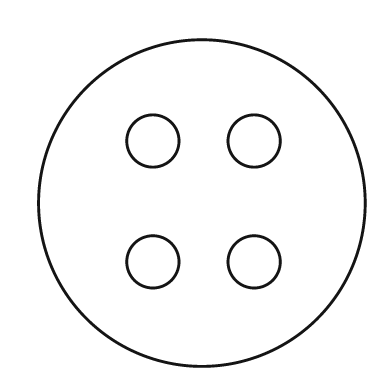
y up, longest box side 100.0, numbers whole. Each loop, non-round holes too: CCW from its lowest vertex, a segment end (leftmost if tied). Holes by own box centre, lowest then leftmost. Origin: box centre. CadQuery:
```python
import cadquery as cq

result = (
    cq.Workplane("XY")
    .moveTo(0.0, 0.0)
    .circle(50.0)
    .moveTo(-15.0, -18.0)
    .circle(8.0)
    .moveTo(16.0, -18.0)
    .circle(8.0)
    .moveTo(-15.0, 19.0)
    .circle(8.0)
    .moveTo(16.0, 19.0)
    .circle(8.0)
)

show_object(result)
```